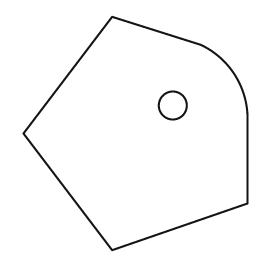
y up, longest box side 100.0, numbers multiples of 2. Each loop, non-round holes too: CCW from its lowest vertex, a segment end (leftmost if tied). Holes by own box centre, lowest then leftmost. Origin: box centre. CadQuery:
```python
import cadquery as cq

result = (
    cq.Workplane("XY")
    .moveTo(-10.0, -50.0)
    .lineTo(48.0, -30.0)
    .lineTo(48.0, 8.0)
    .threePointArc((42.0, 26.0), (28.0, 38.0))
    .lineTo(-10.0, 50.0)
    .lineTo(-48.0, 0.0)
    .close()
    .moveTo(16.0, 12.0)
    .circle(6.0)
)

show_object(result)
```